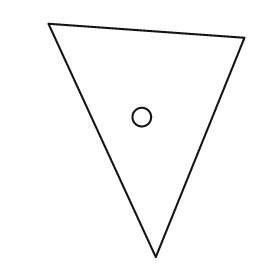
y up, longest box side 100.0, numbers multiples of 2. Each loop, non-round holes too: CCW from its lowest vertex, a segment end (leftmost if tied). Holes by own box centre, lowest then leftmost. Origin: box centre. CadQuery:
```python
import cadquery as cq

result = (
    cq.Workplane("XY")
    .moveTo(4.0, -50.0)
    .lineTo(42.0, 44.0)
    .lineTo(-42.0, 50.0)
    .close()
    .moveTo(-2.0, 10.0)
    .circle(4.0)
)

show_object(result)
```